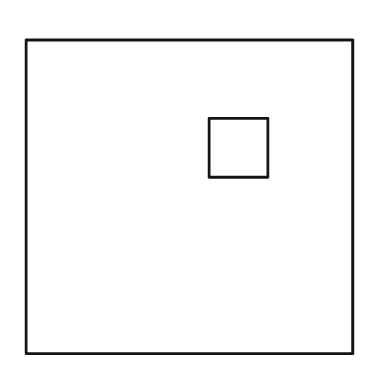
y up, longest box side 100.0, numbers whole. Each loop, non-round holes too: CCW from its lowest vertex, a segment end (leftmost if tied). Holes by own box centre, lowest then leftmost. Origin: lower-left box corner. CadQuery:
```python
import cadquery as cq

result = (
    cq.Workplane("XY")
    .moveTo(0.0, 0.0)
    .lineTo(100.0, 0.0)
    .lineTo(100.0, 96.0)
    .lineTo(0.0, 96.0)
    .close()
    .moveTo(56.0, 54.0)
    .lineTo(74.0, 54.0)
    .lineTo(74.0, 72.0)
    .lineTo(56.0, 72.0)
    .close()
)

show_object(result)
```